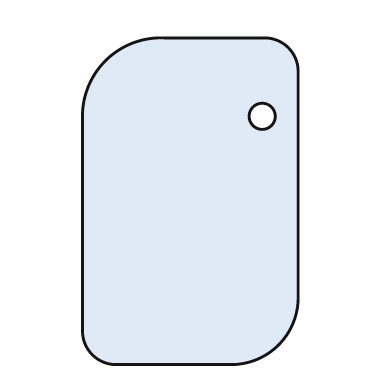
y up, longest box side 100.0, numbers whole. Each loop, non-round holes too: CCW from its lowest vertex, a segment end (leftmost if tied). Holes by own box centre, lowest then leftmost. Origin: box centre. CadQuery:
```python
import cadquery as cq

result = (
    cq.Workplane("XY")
    .moveTo(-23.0, -50.0)
    .lineTo(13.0, -50.0)
    .threePointArc((27.0, -44.0), (33.0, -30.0))
    .lineTo(33.0, 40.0)
    .threePointArc((30.0, 47.0), (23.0, 50.0))
    .lineTo(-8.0, 50.0)
    .threePointArc((-26.0, 43.0), (-33.0, 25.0))
    .lineTo(-33.0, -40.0)
    .threePointArc((-30.0, -47.0), (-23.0, -50.0))
    .close()
    .moveTo(22.0, 26.0)
    .circle(4.0)
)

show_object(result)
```